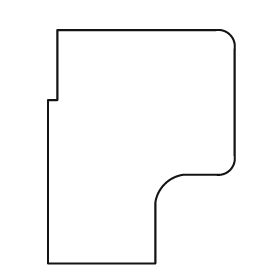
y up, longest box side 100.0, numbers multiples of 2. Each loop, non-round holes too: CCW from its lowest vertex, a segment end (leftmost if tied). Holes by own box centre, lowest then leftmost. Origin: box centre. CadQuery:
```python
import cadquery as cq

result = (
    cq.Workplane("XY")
    .moveTo(-40.0, -50.0)
    .lineTo(6.0, -50.0)
    .lineTo(6.0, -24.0)
    .threePointArc((10.0, -16.0), (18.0, -12.0))
    .lineTo(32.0, -12.0)
    .threePointArc((38.0, -10.0), (40.0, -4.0))
    .lineTo(40.0, 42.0)
    .threePointArc((38.0, 48.0), (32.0, 50.0))
    .lineTo(-36.0, 50.0)
    .lineTo(-36.0, 20.0)
    .lineTo(-40.0, 20.0)
    .close()
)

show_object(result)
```